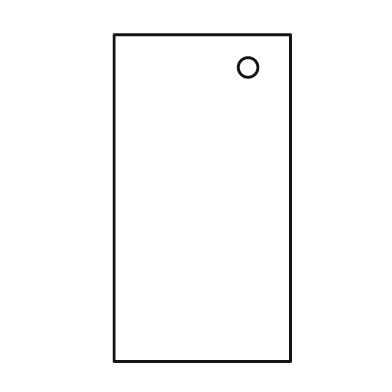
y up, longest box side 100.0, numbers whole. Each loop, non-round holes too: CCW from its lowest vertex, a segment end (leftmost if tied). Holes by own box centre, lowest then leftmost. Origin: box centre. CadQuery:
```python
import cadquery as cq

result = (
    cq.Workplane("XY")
    .moveTo(-27.0, -50.0)
    .lineTo(27.0, -50.0)
    .lineTo(27.0, 50.0)
    .lineTo(-27.0, 50.0)
    .close()
    .moveTo(14.0, 40.0)
    .circle(3.0)
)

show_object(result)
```